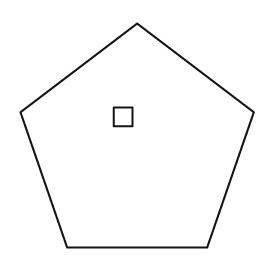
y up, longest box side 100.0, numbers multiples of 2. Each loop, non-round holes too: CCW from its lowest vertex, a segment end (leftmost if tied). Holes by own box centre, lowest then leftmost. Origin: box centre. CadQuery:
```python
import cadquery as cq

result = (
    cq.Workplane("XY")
    .moveTo(-30.0, -48.0)
    .lineTo(30.0, -48.0)
    .lineTo(50.0, 10.0)
    .lineTo(0.0, 48.0)
    .lineTo(-50.0, 10.0)
    .close()
    .moveTo(-10.0, 4.0)
    .lineTo(-2.0, 4.0)
    .lineTo(-2.0, 12.0)
    .lineTo(-10.0, 12.0)
    .close()
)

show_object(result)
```